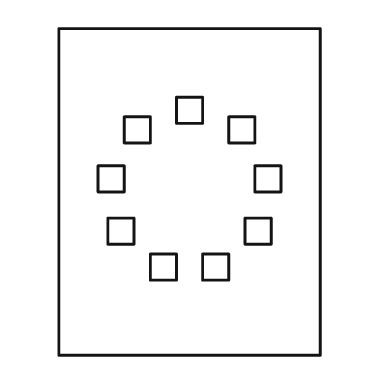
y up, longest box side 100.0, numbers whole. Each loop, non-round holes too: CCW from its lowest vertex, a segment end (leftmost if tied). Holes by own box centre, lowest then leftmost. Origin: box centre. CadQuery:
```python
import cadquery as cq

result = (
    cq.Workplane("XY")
    .moveTo(-40.0, -50.0)
    .lineTo(40.0, -50.0)
    .lineTo(40.0, 50.0)
    .lineTo(-40.0, 50.0)
    .close()
    .moveTo(-12.0, -27.0)
    .lineTo(-4.0, -27.0)
    .lineTo(-4.0, -19.0)
    .lineTo(-12.0, -19.0)
    .close()
    .moveTo(4.0, -27.0)
    .lineTo(12.0, -27.0)
    .lineTo(12.0, -19.0)
    .lineTo(4.0, -19.0)
    .close()
    .moveTo(-25.0, -16.0)
    .lineTo(-17.0, -16.0)
    .lineTo(-17.0, -8.0)
    .lineTo(-25.0, -8.0)
    .close()
    .moveTo(17.0, -16.0)
    .lineTo(25.0, -16.0)
    .lineTo(25.0, -8.0)
    .lineTo(17.0, -8.0)
    .close()
    .moveTo(-28.0, 0.0)
    .lineTo(-20.0, 0.0)
    .lineTo(-20.0, 8.0)
    .lineTo(-28.0, 8.0)
    .close()
    .moveTo(20.0, 0.0)
    .lineTo(28.0, 0.0)
    .lineTo(28.0, 8.0)
    .lineTo(20.0, 8.0)
    .close()
    .moveTo(-20.0, 15.0)
    .lineTo(-12.0, 15.0)
    .lineTo(-12.0, 23.0)
    .lineTo(-20.0, 23.0)
    .close()
    .moveTo(12.0, 15.0)
    .lineTo(20.0, 15.0)
    .lineTo(20.0, 23.0)
    .lineTo(12.0, 23.0)
    .close()
    .moveTo(-4.0, 21.0)
    .lineTo(4.0, 21.0)
    .lineTo(4.0, 29.0)
    .lineTo(-4.0, 29.0)
    .close()
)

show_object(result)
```